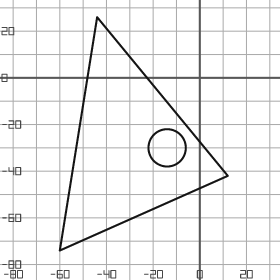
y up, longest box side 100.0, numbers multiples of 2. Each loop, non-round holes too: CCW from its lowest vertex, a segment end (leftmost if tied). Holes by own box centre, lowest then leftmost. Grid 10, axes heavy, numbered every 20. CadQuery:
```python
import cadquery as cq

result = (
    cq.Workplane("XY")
    .moveTo(-60.0, -74.0)
    .lineTo(12.0, -42.0)
    .lineTo(-44.0, 26.0)
    .close()
    .moveTo(-14.0, -30.0)
    .circle(8.0)
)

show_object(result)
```